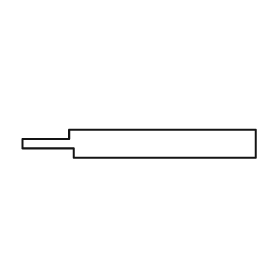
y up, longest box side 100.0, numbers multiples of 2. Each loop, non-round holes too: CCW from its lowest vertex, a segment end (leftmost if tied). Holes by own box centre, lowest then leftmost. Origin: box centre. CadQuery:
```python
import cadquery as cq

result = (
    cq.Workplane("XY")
    .moveTo(-28.0, -6.0)
    .lineTo(50.0, -6.0)
    .lineTo(50.0, 6.0)
    .lineTo(-30.0, 6.0)
    .lineTo(-30.0, 2.0)
    .lineTo(-50.0, 2.0)
    .lineTo(-50.0, -2.0)
    .lineTo(-28.0, -2.0)
    .close()
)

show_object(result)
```